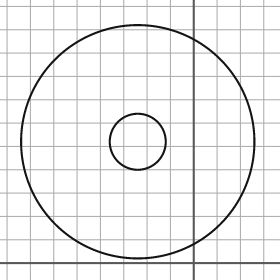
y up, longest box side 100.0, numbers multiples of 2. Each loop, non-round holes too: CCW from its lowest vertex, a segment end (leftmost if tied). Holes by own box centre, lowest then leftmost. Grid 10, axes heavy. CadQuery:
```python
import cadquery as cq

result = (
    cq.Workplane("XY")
    .moveTo(-24.0, 52.0)
    .circle(50.0)
    .moveTo(-24.0, 52.0)
    .circle(12.0)
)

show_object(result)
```